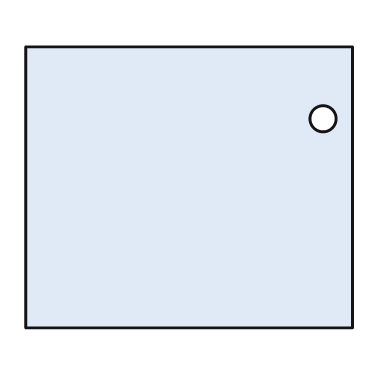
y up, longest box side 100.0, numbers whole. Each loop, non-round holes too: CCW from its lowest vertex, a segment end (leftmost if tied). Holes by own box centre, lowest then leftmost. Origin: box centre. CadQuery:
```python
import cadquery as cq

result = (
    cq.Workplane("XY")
    .moveTo(-50.0, -43.0)
    .lineTo(50.0, -43.0)
    .lineTo(50.0, 43.0)
    .lineTo(-50.0, 43.0)
    .close()
    .moveTo(41.0, 21.0)
    .circle(4.0)
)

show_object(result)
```